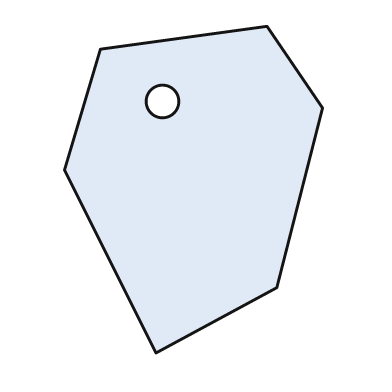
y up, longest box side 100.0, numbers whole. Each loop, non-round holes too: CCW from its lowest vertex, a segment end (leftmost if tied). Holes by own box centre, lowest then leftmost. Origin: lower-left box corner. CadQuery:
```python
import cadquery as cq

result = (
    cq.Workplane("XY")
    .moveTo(28.0, 0.0)
    .lineTo(65.0, 20.0)
    .lineTo(79.0, 75.0)
    .lineTo(62.0, 100.0)
    .lineTo(11.0, 93.0)
    .lineTo(0.0, 56.0)
    .close()
    .moveTo(30.0, 77.0)
    .circle(5.0)
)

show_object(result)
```